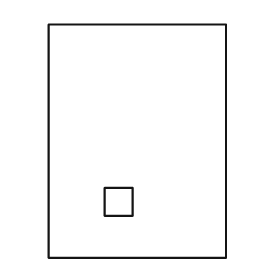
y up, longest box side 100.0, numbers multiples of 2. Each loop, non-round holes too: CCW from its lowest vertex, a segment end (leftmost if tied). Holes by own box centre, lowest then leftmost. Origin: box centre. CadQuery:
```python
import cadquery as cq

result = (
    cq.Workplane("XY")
    .moveTo(-38.0, -50.0)
    .lineTo(38.0, -50.0)
    .lineTo(38.0, 50.0)
    .lineTo(-38.0, 50.0)
    .close()
    .moveTo(-14.0, -32.0)
    .lineTo(-2.0, -32.0)
    .lineTo(-2.0, -20.0)
    .lineTo(-14.0, -20.0)
    .close()
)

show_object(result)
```